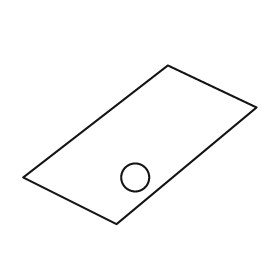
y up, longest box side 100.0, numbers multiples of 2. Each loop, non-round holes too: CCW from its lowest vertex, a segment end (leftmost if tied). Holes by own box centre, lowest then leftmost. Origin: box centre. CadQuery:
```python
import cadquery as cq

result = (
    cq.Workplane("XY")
    .moveTo(-10.0, -34.0)
    .lineTo(50.0, 16.0)
    .lineTo(12.0, 34.0)
    .lineTo(-50.0, -14.0)
    .close()
    .moveTo(-2.0, -14.0)
    .circle(6.0)
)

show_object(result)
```